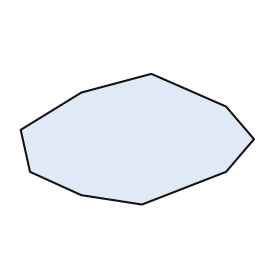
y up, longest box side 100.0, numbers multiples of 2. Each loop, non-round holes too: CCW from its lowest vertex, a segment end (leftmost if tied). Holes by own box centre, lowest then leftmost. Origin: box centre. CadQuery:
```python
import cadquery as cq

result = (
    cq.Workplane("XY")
    .moveTo(2.0, -28.0)
    .lineTo(38.0, -14.0)
    .lineTo(50.0, 0.0)
    .lineTo(38.0, 14.0)
    .lineTo(6.0, 28.0)
    .lineTo(-24.0, 20.0)
    .lineTo(-50.0, 4.0)
    .lineTo(-46.0, -14.0)
    .lineTo(-24.0, -24.0)
    .close()
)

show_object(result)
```